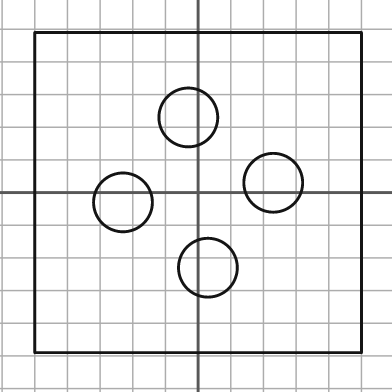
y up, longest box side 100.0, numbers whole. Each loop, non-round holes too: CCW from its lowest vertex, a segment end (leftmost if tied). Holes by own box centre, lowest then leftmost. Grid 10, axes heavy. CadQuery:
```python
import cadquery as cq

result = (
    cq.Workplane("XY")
    .moveTo(-50.0, -49.0)
    .lineTo(50.0, -49.0)
    .lineTo(50.0, 49.0)
    .lineTo(-50.0, 49.0)
    .close()
    .moveTo(3.0, -23.0)
    .circle(9.0)
    .moveTo(-23.0, -3.0)
    .circle(9.0)
    .moveTo(23.0, 3.0)
    .circle(9.0)
    .moveTo(-3.0, 23.0)
    .circle(9.0)
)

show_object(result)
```